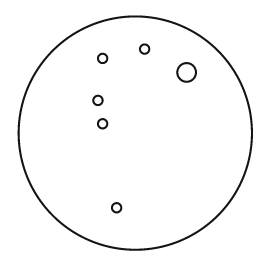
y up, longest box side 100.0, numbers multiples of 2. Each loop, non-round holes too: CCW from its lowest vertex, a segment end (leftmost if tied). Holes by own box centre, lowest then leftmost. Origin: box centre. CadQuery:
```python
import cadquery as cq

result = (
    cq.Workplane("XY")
    .moveTo(0.0, 0.0)
    .circle(50.0)
    .moveTo(-8.0, -32.0)
    .circle(2.0)
    .moveTo(-14.0, 4.0)
    .circle(2.0)
    .moveTo(-16.0, 14.0)
    .circle(2.0)
    .moveTo(22.0, 26.0)
    .circle(4.0)
    .moveTo(-14.0, 32.0)
    .circle(2.0)
    .moveTo(4.0, 36.0)
    .circle(2.0)
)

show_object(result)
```